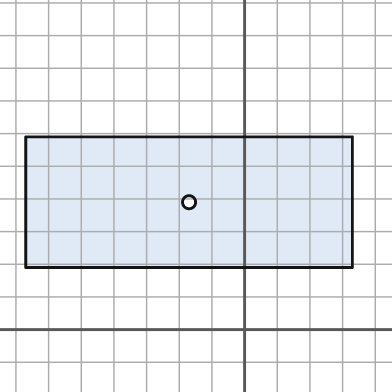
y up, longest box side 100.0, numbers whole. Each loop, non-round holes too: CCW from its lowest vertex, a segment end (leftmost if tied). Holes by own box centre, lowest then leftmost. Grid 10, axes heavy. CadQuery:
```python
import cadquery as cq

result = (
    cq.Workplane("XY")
    .moveTo(-67.0, 19.0)
    .lineTo(33.0, 19.0)
    .lineTo(33.0, 59.0)
    .lineTo(-67.0, 59.0)
    .close()
    .moveTo(-17.0, 39.0)
    .circle(2.0)
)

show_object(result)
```